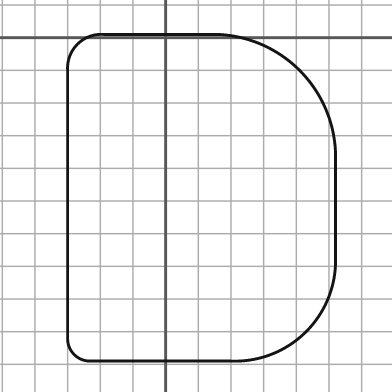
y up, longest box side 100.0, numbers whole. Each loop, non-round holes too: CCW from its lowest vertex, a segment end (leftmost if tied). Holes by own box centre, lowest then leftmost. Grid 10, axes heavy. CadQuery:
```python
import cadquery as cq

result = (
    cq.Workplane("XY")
    .moveTo(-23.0, -99.0)
    .lineTo(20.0, -99.0)
    .threePointArc((43.0, -90.0), (52.0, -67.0))
    .lineTo(52.0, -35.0)
    .threePointArc((41.0, -10.0), (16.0, 1.0))
    .lineTo(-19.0, 1.0)
    .threePointArc((-27.0, -2.0), (-30.0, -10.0))
    .lineTo(-30.0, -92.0)
    .threePointArc((-28.0, -97.0), (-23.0, -99.0))
    .close()
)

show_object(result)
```